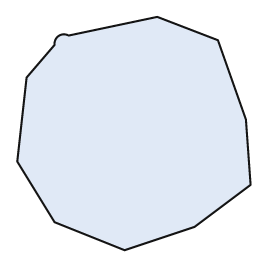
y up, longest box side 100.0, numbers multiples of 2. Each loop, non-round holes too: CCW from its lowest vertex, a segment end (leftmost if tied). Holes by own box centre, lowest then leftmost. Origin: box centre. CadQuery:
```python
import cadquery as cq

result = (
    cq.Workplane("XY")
    .moveTo(-4.0, -50.0)
    .lineTo(26.0, -40.0)
    .lineTo(50.0, -22.0)
    .lineTo(48.0, 6.0)
    .lineTo(36.0, 40.0)
    .lineTo(10.0, 50.0)
    .lineTo(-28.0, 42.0)
    .threePointArc((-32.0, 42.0), (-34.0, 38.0))
    .lineTo(-46.0, 24.0)
    .lineTo(-50.0, -12.0)
    .lineTo(-34.0, -38.0)
    .close()
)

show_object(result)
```